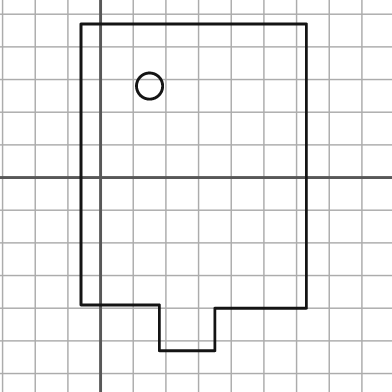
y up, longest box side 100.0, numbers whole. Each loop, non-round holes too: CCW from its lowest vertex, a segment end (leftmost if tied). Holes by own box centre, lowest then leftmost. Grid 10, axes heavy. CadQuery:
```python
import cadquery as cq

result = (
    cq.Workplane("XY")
    .moveTo(18.0, -53.0)
    .lineTo(35.0, -53.0)
    .lineTo(35.0, -40.0)
    .lineTo(63.0, -40.0)
    .lineTo(63.0, 47.0)
    .lineTo(-6.0, 47.0)
    .lineTo(-6.0, -39.0)
    .lineTo(18.0, -39.0)
    .close()
    .moveTo(15.0, 28.0)
    .circle(4.0)
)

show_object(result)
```